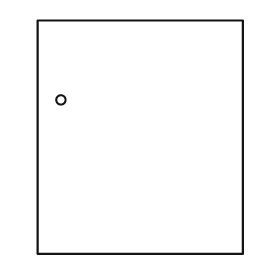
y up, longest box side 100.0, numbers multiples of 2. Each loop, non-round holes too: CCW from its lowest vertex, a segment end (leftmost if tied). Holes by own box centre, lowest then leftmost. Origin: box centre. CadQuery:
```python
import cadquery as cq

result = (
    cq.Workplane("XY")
    .moveTo(-44.0, -50.0)
    .lineTo(44.0, -50.0)
    .lineTo(44.0, 50.0)
    .lineTo(-44.0, 50.0)
    .close()
    .moveTo(-34.0, 16.0)
    .circle(2.0)
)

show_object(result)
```